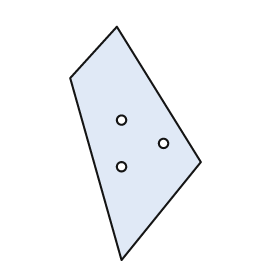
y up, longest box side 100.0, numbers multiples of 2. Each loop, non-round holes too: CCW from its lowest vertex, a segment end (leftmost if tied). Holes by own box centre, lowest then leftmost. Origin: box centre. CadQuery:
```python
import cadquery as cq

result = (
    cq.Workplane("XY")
    .moveTo(-6.0, -50.0)
    .lineTo(28.0, -8.0)
    .lineTo(-8.0, 50.0)
    .lineTo(-28.0, 28.0)
    .close()
    .moveTo(-6.0, -10.0)
    .circle(2.0)
    .moveTo(12.0, 0.0)
    .circle(2.0)
    .moveTo(-6.0, 10.0)
    .circle(2.0)
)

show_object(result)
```